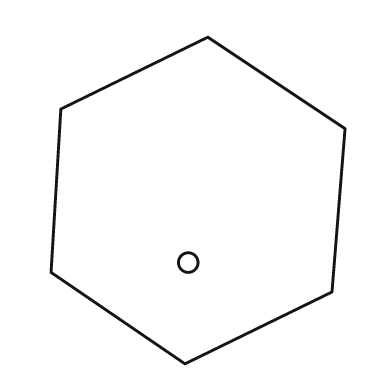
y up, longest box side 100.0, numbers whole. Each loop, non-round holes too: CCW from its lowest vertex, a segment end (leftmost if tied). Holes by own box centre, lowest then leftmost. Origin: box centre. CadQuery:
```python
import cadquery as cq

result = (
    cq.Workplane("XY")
    .moveTo(-4.0, -50.0)
    .lineTo(41.0, -28.0)
    .lineTo(45.0, 22.0)
    .lineTo(3.0, 50.0)
    .lineTo(-42.0, 28.0)
    .lineTo(-45.0, -22.0)
    .close()
    .moveTo(-3.0, -19.0)
    .circle(3.0)
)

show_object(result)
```